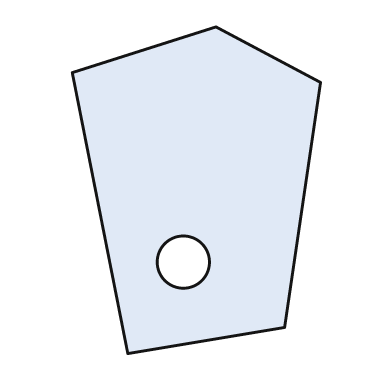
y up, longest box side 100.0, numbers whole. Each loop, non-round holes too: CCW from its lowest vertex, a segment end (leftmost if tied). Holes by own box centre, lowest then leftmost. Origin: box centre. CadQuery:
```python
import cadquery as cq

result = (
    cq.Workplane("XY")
    .moveTo(-21.0, -50.0)
    .lineTo(27.0, -42.0)
    .lineTo(38.0, 33.0)
    .lineTo(6.0, 50.0)
    .lineTo(-38.0, 36.0)
    .close()
    .moveTo(-4.0, -22.0)
    .circle(8.0)
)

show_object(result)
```